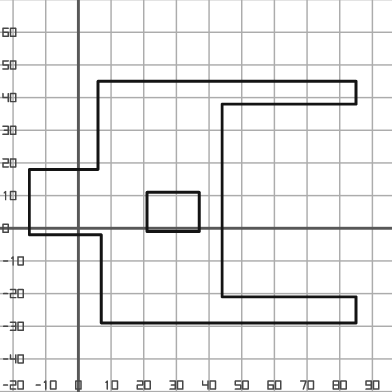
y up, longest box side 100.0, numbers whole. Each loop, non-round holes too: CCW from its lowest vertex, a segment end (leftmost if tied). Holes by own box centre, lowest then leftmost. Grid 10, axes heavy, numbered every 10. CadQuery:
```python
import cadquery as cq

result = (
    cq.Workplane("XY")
    .moveTo(7.0, -29.0)
    .lineTo(85.0, -29.0)
    .lineTo(85.0, -21.0)
    .lineTo(44.0, -21.0)
    .lineTo(44.0, 38.0)
    .lineTo(85.0, 38.0)
    .lineTo(85.0, 45.0)
    .lineTo(6.0, 45.0)
    .lineTo(6.0, 18.0)
    .lineTo(-15.0, 18.0)
    .lineTo(-15.0, -2.0)
    .lineTo(7.0, -2.0)
    .close()
    .moveTo(21.0, -1.0)
    .lineTo(37.0, -1.0)
    .lineTo(37.0, 11.0)
    .lineTo(21.0, 11.0)
    .close()
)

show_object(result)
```